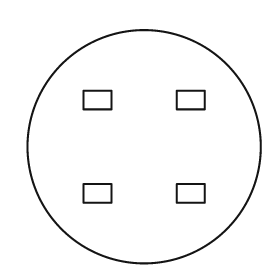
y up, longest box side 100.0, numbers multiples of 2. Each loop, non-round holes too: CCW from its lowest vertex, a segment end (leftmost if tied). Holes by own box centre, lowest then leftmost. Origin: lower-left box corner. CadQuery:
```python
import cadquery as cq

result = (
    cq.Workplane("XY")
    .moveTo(50.0, 50.0)
    .circle(50.0)
    .moveTo(24.0, 26.0)
    .lineTo(36.0, 26.0)
    .lineTo(36.0, 34.0)
    .lineTo(24.0, 34.0)
    .close()
    .moveTo(64.0, 26.0)
    .lineTo(76.0, 26.0)
    .lineTo(76.0, 34.0)
    .lineTo(64.0, 34.0)
    .close()
    .moveTo(24.0, 66.0)
    .lineTo(36.0, 66.0)
    .lineTo(36.0, 74.0)
    .lineTo(24.0, 74.0)
    .close()
    .moveTo(64.0, 66.0)
    .lineTo(76.0, 66.0)
    .lineTo(76.0, 74.0)
    .lineTo(64.0, 74.0)
    .close()
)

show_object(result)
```